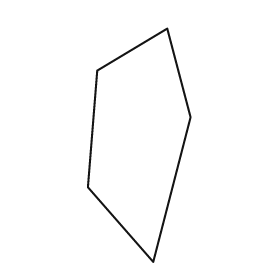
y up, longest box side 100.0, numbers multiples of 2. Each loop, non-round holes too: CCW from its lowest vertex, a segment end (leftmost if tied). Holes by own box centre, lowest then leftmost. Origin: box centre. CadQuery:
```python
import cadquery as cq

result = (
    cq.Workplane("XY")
    .moveTo(6.0, -50.0)
    .lineTo(22.0, 12.0)
    .lineTo(12.0, 50.0)
    .lineTo(-18.0, 32.0)
    .lineTo(-22.0, -18.0)
    .close()
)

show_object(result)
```